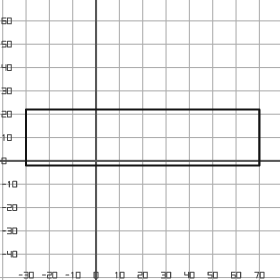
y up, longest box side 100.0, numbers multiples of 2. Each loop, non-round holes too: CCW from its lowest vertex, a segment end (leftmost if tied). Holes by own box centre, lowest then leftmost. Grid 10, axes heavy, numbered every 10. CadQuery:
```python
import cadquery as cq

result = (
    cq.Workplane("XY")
    .moveTo(-30.0, -2.0)
    .lineTo(70.0, -2.0)
    .lineTo(70.0, 22.0)
    .lineTo(-30.0, 22.0)
    .close()
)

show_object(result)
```